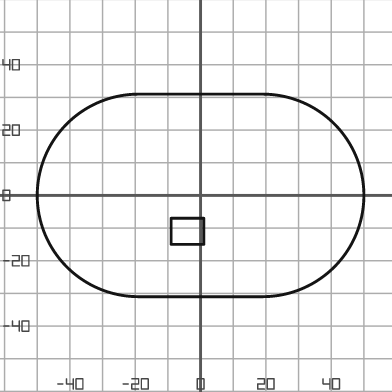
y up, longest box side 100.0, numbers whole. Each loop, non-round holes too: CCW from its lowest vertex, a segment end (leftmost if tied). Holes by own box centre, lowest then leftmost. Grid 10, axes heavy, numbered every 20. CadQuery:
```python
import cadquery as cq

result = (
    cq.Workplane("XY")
    .moveTo(-19.0, -31.0)
    .lineTo(19.0, -31.0)
    .threePointArc((50.0, 0.0), (19.0, 31.0))
    .lineTo(-19.0, 31.0)
    .threePointArc((-50.0, 0.0), (-19.0, -31.0))
    .close()
    .moveTo(-9.0, -15.0)
    .lineTo(1.0, -15.0)
    .lineTo(1.0, -7.0)
    .lineTo(-9.0, -7.0)
    .close()
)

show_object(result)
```